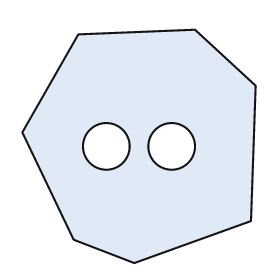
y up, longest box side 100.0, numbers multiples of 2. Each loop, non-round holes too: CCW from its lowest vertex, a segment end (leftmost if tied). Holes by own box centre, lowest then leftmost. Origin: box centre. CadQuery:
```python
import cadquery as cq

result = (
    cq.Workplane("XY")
    .moveTo(-2.0, -50.0)
    .lineTo(48.0, -32.0)
    .lineTo(50.0, 26.0)
    .lineTo(24.0, 50.0)
    .lineTo(-26.0, 48.0)
    .lineTo(-50.0, 6.0)
    .lineTo(-28.0, -40.0)
    .close()
    .moveTo(-14.0, 0.0)
    .circle(10.0)
    .moveTo(14.0, 0.0)
    .circle(10.0)
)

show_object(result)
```